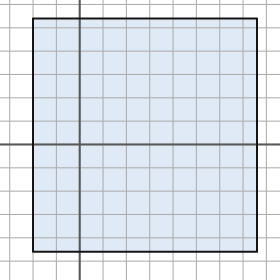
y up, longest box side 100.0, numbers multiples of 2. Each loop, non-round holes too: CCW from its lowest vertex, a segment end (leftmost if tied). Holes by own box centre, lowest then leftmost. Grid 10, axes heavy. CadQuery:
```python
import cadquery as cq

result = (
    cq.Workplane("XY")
    .moveTo(-20.0, -46.0)
    .lineTo(76.0, -46.0)
    .lineTo(76.0, 54.0)
    .lineTo(-20.0, 54.0)
    .close()
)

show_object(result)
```